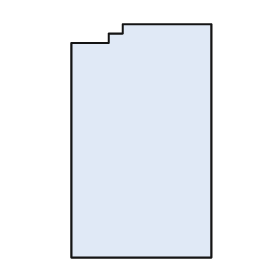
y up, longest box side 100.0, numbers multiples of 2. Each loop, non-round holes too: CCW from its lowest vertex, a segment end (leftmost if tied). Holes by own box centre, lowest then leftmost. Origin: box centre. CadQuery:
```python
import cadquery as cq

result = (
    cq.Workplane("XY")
    .moveTo(-30.0, -50.0)
    .lineTo(30.0, -50.0)
    .lineTo(30.0, 50.0)
    .lineTo(-8.0, 50.0)
    .lineTo(-8.0, 46.0)
    .lineTo(-14.0, 46.0)
    .lineTo(-14.0, 42.0)
    .lineTo(-30.0, 42.0)
    .close()
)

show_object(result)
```